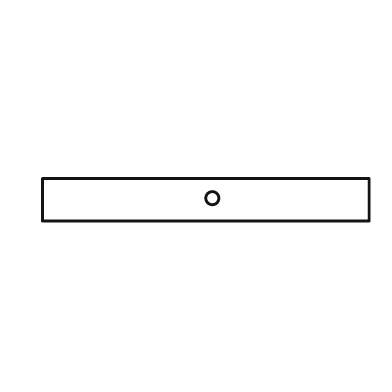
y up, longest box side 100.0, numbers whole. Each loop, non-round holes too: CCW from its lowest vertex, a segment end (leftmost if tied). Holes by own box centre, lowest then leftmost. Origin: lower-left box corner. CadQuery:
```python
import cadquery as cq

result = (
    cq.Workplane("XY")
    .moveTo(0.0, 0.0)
    .lineTo(100.0, 0.0)
    .lineTo(100.0, 13.0)
    .lineTo(0.0, 13.0)
    .close()
    .moveTo(52.0, 7.0)
    .circle(2.0)
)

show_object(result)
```